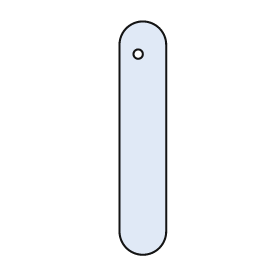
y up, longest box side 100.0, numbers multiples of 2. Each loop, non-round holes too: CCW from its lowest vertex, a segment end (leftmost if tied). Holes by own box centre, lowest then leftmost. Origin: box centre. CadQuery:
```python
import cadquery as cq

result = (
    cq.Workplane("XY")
    .moveTo(-10.0, -40.0)
    .threePointArc((0.0, -50.0), (10.0, -40.0))
    .lineTo(10.0, 40.0)
    .threePointArc((0.0, 50.0), (-10.0, 40.0))
    .close()
    .moveTo(-2.0, 36.0)
    .circle(2.0)
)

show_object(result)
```